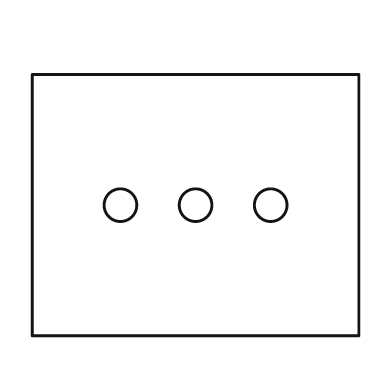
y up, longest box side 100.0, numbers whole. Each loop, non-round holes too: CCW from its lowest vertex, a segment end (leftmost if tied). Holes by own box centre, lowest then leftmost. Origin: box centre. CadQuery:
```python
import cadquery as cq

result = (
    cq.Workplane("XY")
    .moveTo(-50.0, -40.0)
    .lineTo(50.0, -40.0)
    .lineTo(50.0, 40.0)
    .lineTo(-50.0, 40.0)
    .close()
    .moveTo(-23.0, 0.0)
    .circle(5.0)
    .moveTo(0.0, 0.0)
    .circle(5.0)
    .moveTo(23.0, 0.0)
    .circle(5.0)
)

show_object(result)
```